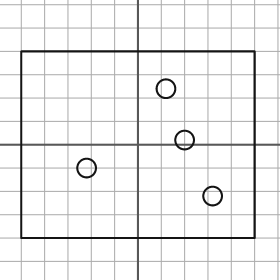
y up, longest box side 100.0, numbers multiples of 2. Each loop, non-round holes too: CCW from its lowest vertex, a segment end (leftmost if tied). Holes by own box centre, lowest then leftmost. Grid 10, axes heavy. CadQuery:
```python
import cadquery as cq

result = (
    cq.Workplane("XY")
    .moveTo(-50.0, -40.0)
    .lineTo(50.0, -40.0)
    .lineTo(50.0, 40.0)
    .lineTo(-50.0, 40.0)
    .close()
    .moveTo(32.0, -22.0)
    .circle(4.0)
    .moveTo(-22.0, -10.0)
    .circle(4.0)
    .moveTo(20.0, 2.0)
    .circle(4.0)
    .moveTo(12.0, 24.0)
    .circle(4.0)
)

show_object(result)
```